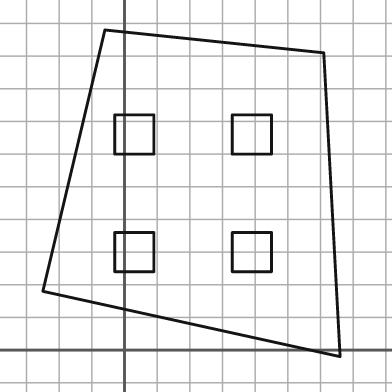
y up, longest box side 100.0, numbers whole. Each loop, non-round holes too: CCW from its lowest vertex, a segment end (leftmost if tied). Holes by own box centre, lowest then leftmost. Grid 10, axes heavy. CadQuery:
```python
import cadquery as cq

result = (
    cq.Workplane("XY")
    .moveTo(66.0, -2.0)
    .lineTo(61.0, 91.0)
    .lineTo(-6.0, 98.0)
    .lineTo(-25.0, 18.0)
    .close()
    .moveTo(-3.0, 24.0)
    .lineTo(9.0, 24.0)
    .lineTo(9.0, 36.0)
    .lineTo(-3.0, 36.0)
    .close()
    .moveTo(33.0, 24.0)
    .lineTo(45.0, 24.0)
    .lineTo(45.0, 36.0)
    .lineTo(33.0, 36.0)
    .close()
    .moveTo(-3.0, 60.0)
    .lineTo(9.0, 60.0)
    .lineTo(9.0, 72.0)
    .lineTo(-3.0, 72.0)
    .close()
    .moveTo(33.0, 60.0)
    .lineTo(45.0, 60.0)
    .lineTo(45.0, 72.0)
    .lineTo(33.0, 72.0)
    .close()
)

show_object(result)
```